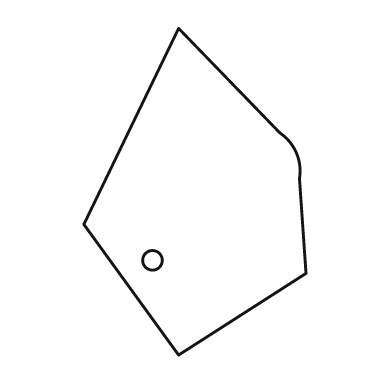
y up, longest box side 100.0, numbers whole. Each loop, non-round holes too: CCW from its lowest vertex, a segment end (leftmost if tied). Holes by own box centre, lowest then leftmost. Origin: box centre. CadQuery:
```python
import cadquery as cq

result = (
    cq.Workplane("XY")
    .moveTo(-5.0, -50.0)
    .lineTo(34.0, -25.0)
    .lineTo(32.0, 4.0)
    .threePointArc((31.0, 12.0), (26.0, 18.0))
    .lineTo(-5.0, 50.0)
    .lineTo(-34.0, -10.0)
    .close()
    .moveTo(-13.0, -21.0)
    .circle(3.0)
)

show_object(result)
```